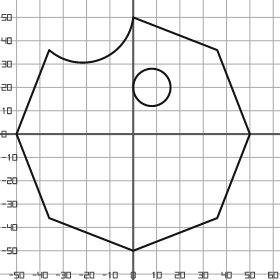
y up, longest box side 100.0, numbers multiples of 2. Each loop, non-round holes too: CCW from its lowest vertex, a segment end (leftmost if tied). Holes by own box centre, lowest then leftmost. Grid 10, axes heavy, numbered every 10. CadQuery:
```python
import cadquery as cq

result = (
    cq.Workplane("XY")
    .moveTo(0.0, -50.0)
    .lineTo(36.0, -36.0)
    .lineTo(50.0, 0.0)
    .lineTo(36.0, 36.0)
    .lineTo(0.0, 50.0)
    .threePointArc((-14.0, 32.0), (-36.0, 36.0))
    .lineTo(-50.0, 0.0)
    .lineTo(-36.0, -36.0)
    .close()
    .moveTo(8.0, 20.0)
    .circle(8.0)
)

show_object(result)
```